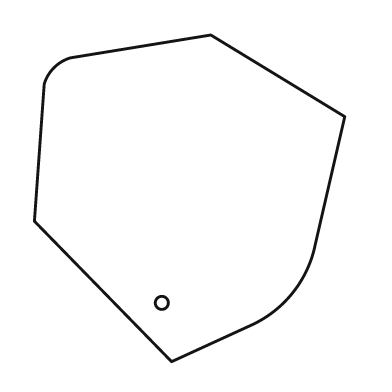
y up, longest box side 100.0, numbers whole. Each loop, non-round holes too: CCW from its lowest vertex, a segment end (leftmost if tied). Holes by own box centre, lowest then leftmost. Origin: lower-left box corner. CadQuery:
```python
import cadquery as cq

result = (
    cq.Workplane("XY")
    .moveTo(42.0, 0.0)
    .lineTo(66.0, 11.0)
    .threePointArc((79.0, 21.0), (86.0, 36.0))
    .lineTo(95.0, 75.0)
    .lineTo(54.0, 100.0)
    .lineTo(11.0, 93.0)
    .threePointArc((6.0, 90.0), (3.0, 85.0))
    .lineTo(0.0, 43.0)
    .close()
    .moveTo(39.0, 18.0)
    .circle(2.0)
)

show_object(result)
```